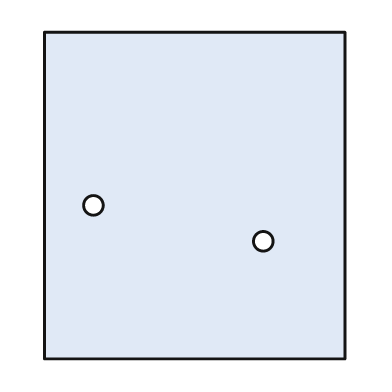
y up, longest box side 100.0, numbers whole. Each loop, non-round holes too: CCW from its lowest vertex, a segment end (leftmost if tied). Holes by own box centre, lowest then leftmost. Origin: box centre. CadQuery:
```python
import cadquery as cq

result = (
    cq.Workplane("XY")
    .moveTo(-46.0, -50.0)
    .lineTo(46.0, -50.0)
    .lineTo(46.0, 50.0)
    .lineTo(-46.0, 50.0)
    .close()
    .moveTo(21.0, -14.0)
    .circle(3.0)
    .moveTo(-31.0, -3.0)
    .circle(3.0)
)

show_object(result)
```